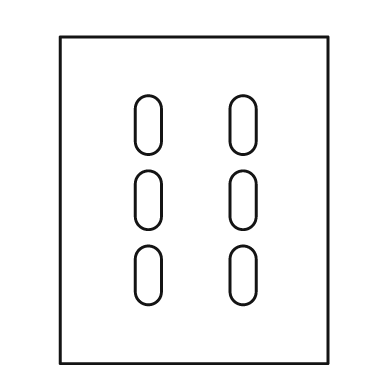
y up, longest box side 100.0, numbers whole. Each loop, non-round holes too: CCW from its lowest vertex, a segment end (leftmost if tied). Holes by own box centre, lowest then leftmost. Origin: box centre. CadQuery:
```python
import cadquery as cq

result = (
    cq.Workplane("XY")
    .moveTo(-41.0, -50.0)
    .lineTo(41.0, -50.0)
    .lineTo(41.0, 50.0)
    .lineTo(-41.0, 50.0)
    .close()
    .moveTo(-18.0, -28.0)
    .threePointArc((-14.0, -32.0), (-10.0, -28.0))
    .lineTo(-10.0, -18.0)
    .threePointArc((-14.0, -14.0), (-18.0, -18.0))
    .close()
    .moveTo(11.0, -28.0)
    .threePointArc((15.0, -32.0), (19.0, -28.0))
    .lineTo(19.0, -18.0)
    .threePointArc((15.0, -14.0), (11.0, -18.0))
    .close()
    .moveTo(-18.0, -5.0)
    .threePointArc((-14.0, -9.0), (-10.0, -5.0))
    .lineTo(-10.0, 5.0)
    .threePointArc((-14.0, 9.0), (-18.0, 5.0))
    .close()
    .moveTo(11.0, -5.0)
    .threePointArc((15.0, -9.0), (19.0, -5.0))
    .lineTo(19.0, 5.0)
    .threePointArc((15.0, 9.0), (11.0, 5.0))
    .close()
    .moveTo(-18.0, 18.0)
    .threePointArc((-14.0, 14.0), (-10.0, 18.0))
    .lineTo(-10.0, 28.0)
    .threePointArc((-14.0, 32.0), (-18.0, 28.0))
    .close()
    .moveTo(11.0, 18.0)
    .threePointArc((15.0, 14.0), (19.0, 18.0))
    .lineTo(19.0, 28.0)
    .threePointArc((15.0, 32.0), (11.0, 28.0))
    .close()
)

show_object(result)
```